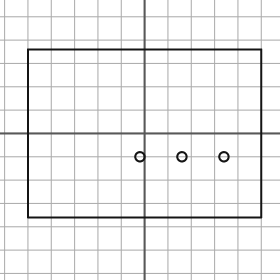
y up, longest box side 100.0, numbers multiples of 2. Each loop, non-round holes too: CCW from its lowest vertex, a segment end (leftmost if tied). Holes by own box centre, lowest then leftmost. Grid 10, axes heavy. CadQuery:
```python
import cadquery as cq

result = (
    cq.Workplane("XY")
    .moveTo(-50.0, -36.0)
    .lineTo(50.0, -36.0)
    .lineTo(50.0, 36.0)
    .lineTo(-50.0, 36.0)
    .close()
    .moveTo(-2.0, -10.0)
    .circle(2.0)
    .moveTo(16.0, -10.0)
    .circle(2.0)
    .moveTo(34.0, -10.0)
    .circle(2.0)
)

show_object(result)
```